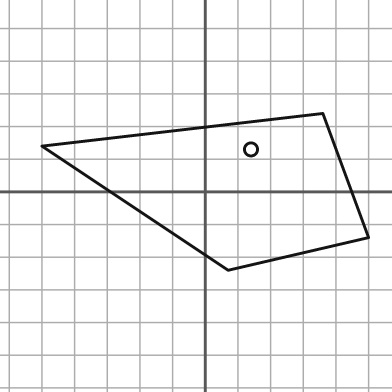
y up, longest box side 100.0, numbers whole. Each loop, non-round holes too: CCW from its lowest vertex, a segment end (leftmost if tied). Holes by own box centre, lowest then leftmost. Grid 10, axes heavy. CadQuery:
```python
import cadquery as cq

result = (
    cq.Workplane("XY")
    .moveTo(7.0, -24.0)
    .lineTo(50.0, -14.0)
    .lineTo(36.0, 24.0)
    .lineTo(-50.0, 14.0)
    .close()
    .moveTo(14.0, 13.0)
    .circle(2.0)
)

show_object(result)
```